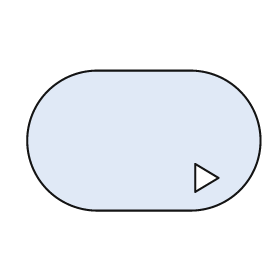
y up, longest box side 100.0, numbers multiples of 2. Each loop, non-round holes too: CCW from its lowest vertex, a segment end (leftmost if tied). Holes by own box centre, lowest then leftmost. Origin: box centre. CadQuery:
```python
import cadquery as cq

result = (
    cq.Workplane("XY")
    .moveTo(-20.0, -30.0)
    .lineTo(20.0, -30.0)
    .threePointArc((50.0, 0.0), (20.0, 30.0))
    .lineTo(-20.0, 30.0)
    .threePointArc((-50.0, 0.0), (-20.0, -30.0))
    .close()
    .moveTo(22.0, -22.0)
    .lineTo(32.0, -16.0)
    .lineTo(22.0, -10.0)
    .close()
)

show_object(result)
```